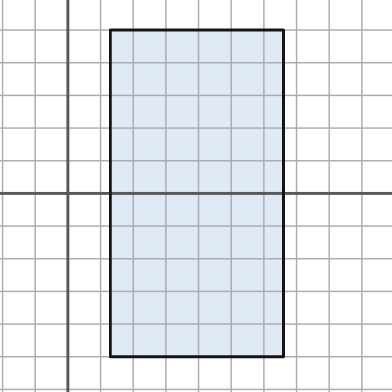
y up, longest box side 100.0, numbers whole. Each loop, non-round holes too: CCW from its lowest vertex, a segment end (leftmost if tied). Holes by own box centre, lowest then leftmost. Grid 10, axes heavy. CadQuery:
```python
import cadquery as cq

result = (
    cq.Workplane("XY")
    .moveTo(13.0, -50.0)
    .lineTo(66.0, -50.0)
    .lineTo(66.0, 50.0)
    .lineTo(13.0, 50.0)
    .close()
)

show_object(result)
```